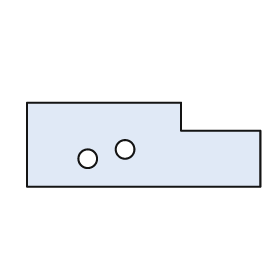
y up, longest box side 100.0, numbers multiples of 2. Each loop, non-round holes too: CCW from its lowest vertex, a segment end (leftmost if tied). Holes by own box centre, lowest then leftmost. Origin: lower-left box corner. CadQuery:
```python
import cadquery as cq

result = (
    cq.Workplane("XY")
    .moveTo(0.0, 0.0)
    .lineTo(100.0, 0.0)
    .lineTo(100.0, 24.0)
    .lineTo(66.0, 24.0)
    .lineTo(66.0, 36.0)
    .lineTo(0.0, 36.0)
    .close()
    .moveTo(26.0, 12.0)
    .circle(4.0)
    .moveTo(42.0, 16.0)
    .circle(4.0)
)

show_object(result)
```